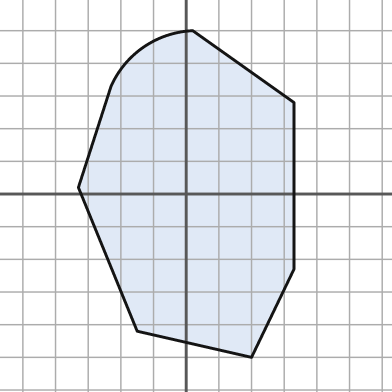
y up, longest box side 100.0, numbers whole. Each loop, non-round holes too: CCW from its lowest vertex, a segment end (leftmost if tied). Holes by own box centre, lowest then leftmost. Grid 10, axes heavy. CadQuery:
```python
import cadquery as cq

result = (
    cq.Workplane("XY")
    .moveTo(20.0, -50.0)
    .lineTo(33.0, -23.0)
    .lineTo(33.0, 28.0)
    .lineTo(2.0, 50.0)
    .threePointArc((-13.0, 45.0), (-23.0, 33.0))
    .lineTo(-33.0, 2.0)
    .lineTo(-15.0, -42.0)
    .close()
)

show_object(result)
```